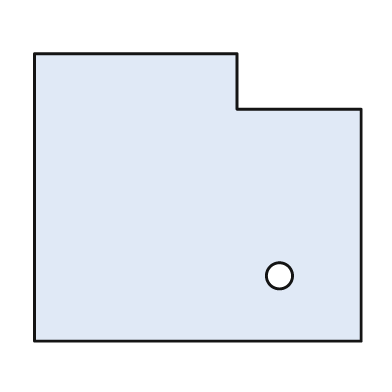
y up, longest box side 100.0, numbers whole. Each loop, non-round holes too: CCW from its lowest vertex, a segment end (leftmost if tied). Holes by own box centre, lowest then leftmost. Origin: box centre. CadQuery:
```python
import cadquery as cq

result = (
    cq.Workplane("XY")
    .moveTo(-50.0, -44.0)
    .lineTo(50.0, -44.0)
    .lineTo(50.0, 27.0)
    .lineTo(12.0, 27.0)
    .lineTo(12.0, 44.0)
    .lineTo(-50.0, 44.0)
    .close()
    .moveTo(25.0, -24.0)
    .circle(4.0)
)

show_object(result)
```